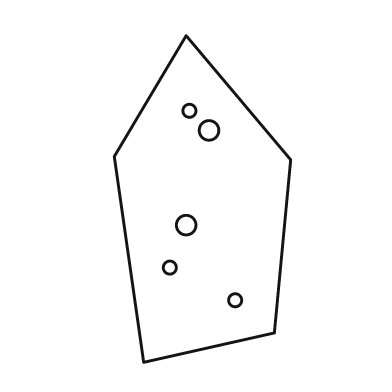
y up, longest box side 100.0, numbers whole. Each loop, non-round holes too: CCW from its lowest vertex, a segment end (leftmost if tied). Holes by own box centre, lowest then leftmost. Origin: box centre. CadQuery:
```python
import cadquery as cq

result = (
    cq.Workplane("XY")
    .moveTo(-18.0, -50.0)
    .lineTo(22.0, -41.0)
    .lineTo(27.0, 12.0)
    .lineTo(-5.0, 50.0)
    .lineTo(-27.0, 13.0)
    .close()
    .moveTo(10.0, -31.0)
    .circle(2.0)
    .moveTo(-10.0, -21.0)
    .circle(2.0)
    .moveTo(-5.0, -8.0)
    .circle(3.0)
    .moveTo(2.0, 21.0)
    .circle(3.0)
    .moveTo(-4.0, 27.0)
    .circle(2.0)
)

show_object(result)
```